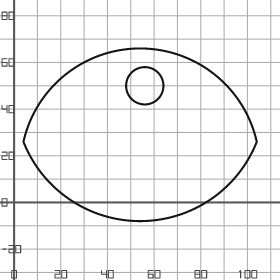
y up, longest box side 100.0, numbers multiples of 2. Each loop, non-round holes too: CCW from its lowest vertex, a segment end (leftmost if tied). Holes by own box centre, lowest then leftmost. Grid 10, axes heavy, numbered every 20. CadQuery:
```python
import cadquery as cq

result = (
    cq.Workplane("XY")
    .moveTo(4.0, 26.0)
    .threePointArc((54.0, -8.0), (104.0, 26.0))
    .threePointArc((54.0, 66.0), (4.0, 26.0))
    .close()
    .moveTo(56.0, 50.0)
    .circle(8.0)
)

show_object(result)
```